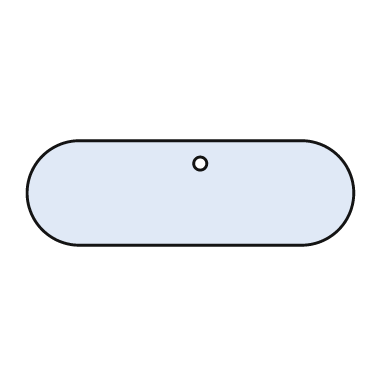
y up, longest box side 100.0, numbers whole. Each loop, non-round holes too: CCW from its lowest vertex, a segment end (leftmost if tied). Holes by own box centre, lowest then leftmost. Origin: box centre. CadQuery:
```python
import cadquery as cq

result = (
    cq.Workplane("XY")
    .moveTo(-34.0, -16.0)
    .lineTo(34.0, -16.0)
    .threePointArc((50.0, 0.0), (34.0, 16.0))
    .lineTo(-34.0, 16.0)
    .threePointArc((-50.0, 0.0), (-34.0, -16.0))
    .close()
    .moveTo(3.0, 9.0)
    .circle(2.0)
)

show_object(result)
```